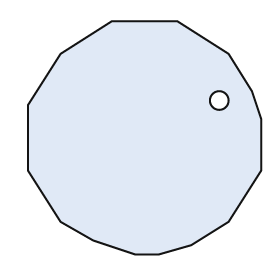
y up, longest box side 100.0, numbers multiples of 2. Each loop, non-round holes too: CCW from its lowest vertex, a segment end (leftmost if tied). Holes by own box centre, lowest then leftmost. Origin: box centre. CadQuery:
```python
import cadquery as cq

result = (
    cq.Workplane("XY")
    .moveTo(-4.0, -50.0)
    .lineTo(6.0, -50.0)
    .lineTo(20.0, -46.0)
    .lineTo(36.0, -36.0)
    .lineTo(50.0, -14.0)
    .lineTo(50.0, 8.0)
    .lineTo(46.0, 20.0)
    .lineTo(36.0, 36.0)
    .lineTo(14.0, 50.0)
    .lineTo(-14.0, 50.0)
    .lineTo(-36.0, 36.0)
    .lineTo(-50.0, 14.0)
    .lineTo(-50.0, -14.0)
    .lineTo(-36.0, -36.0)
    .lineTo(-22.0, -44.0)
    .close()
    .moveTo(32.0, 16.0)
    .circle(4.0)
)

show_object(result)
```